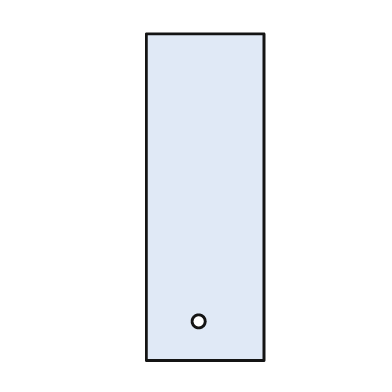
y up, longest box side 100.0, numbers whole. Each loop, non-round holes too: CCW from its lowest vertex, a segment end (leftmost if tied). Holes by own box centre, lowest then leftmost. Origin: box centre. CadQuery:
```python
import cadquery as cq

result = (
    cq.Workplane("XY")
    .moveTo(-18.0, -50.0)
    .lineTo(18.0, -50.0)
    .lineTo(18.0, 50.0)
    .lineTo(-18.0, 50.0)
    .close()
    .moveTo(-2.0, -38.0)
    .circle(2.0)
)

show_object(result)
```